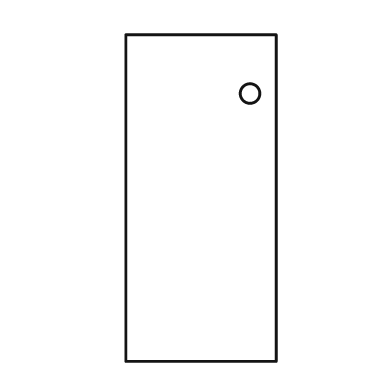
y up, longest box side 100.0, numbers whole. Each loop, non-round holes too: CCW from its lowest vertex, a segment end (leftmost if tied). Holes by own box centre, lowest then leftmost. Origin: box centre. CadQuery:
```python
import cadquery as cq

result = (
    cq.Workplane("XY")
    .moveTo(-23.0, -50.0)
    .lineTo(23.0, -50.0)
    .lineTo(23.0, 50.0)
    .lineTo(-23.0, 50.0)
    .close()
    .moveTo(15.0, 32.0)
    .circle(3.0)
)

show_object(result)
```